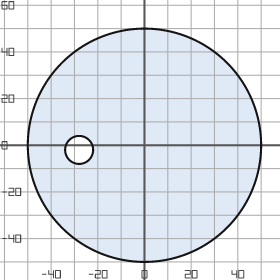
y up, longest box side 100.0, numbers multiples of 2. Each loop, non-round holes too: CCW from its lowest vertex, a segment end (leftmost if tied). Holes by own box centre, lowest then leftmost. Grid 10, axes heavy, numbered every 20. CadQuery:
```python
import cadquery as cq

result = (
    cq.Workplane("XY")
    .moveTo(0.0, 0.0)
    .circle(50.0)
    .moveTo(-28.0, -2.0)
    .circle(6.0)
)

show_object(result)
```